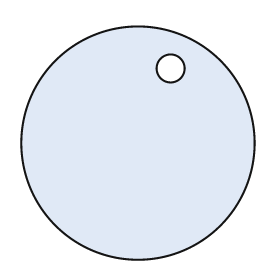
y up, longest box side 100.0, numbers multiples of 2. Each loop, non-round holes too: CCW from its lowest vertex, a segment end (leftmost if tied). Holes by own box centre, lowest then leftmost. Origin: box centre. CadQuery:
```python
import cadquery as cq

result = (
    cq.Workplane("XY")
    .moveTo(0.0, 0.0)
    .circle(50.0)
    .moveTo(14.0, 32.0)
    .circle(6.0)
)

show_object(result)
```